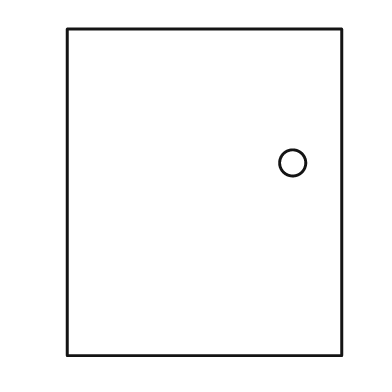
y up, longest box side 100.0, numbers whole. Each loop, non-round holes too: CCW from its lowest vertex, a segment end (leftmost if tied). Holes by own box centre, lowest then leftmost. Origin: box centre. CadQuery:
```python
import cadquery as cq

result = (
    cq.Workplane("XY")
    .moveTo(-42.0, -50.0)
    .lineTo(42.0, -50.0)
    .lineTo(42.0, 50.0)
    .lineTo(-42.0, 50.0)
    .close()
    .moveTo(27.0, 9.0)
    .circle(4.0)
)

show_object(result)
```